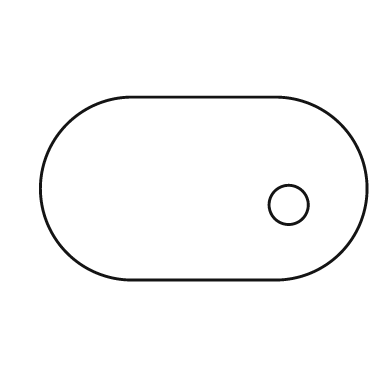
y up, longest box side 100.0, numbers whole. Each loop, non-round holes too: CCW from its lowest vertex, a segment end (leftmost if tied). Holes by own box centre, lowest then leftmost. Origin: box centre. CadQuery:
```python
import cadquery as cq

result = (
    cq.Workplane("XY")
    .moveTo(-22.0, -28.0)
    .lineTo(22.0, -28.0)
    .threePointArc((50.0, 0.0), (22.0, 28.0))
    .lineTo(-22.0, 28.0)
    .threePointArc((-50.0, 0.0), (-22.0, -28.0))
    .close()
    .moveTo(26.0, -5.0)
    .circle(6.0)
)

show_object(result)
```